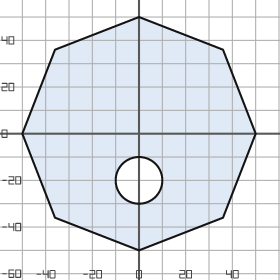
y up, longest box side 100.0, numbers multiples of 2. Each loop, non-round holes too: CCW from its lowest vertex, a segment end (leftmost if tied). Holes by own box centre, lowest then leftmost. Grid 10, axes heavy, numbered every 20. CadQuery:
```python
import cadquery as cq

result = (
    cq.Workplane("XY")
    .moveTo(0.0, -50.0)
    .lineTo(36.0, -36.0)
    .lineTo(50.0, 0.0)
    .lineTo(36.0, 36.0)
    .lineTo(0.0, 50.0)
    .lineTo(-36.0, 36.0)
    .lineTo(-50.0, 0.0)
    .lineTo(-36.0, -36.0)
    .close()
    .moveTo(0.0, -20.0)
    .circle(10.0)
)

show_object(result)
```